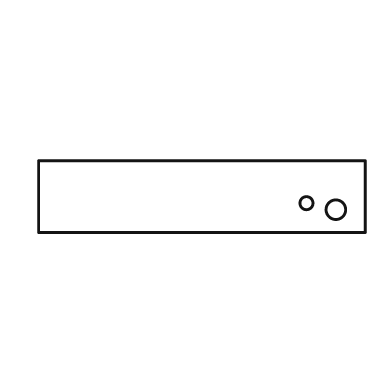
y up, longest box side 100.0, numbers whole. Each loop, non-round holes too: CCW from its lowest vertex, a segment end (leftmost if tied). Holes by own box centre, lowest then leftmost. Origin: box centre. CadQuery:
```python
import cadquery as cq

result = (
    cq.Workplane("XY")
    .moveTo(-50.0, -11.0)
    .lineTo(50.0, -11.0)
    .lineTo(50.0, 11.0)
    .lineTo(-50.0, 11.0)
    .close()
    .moveTo(41.0, -4.0)
    .circle(3.0)
    .moveTo(32.0, -2.0)
    .circle(2.0)
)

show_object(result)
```